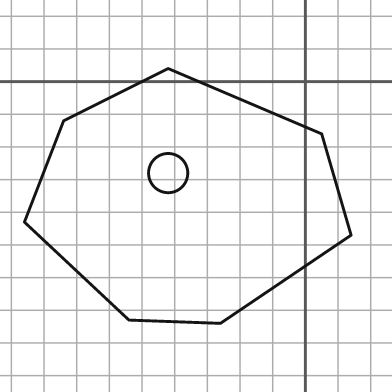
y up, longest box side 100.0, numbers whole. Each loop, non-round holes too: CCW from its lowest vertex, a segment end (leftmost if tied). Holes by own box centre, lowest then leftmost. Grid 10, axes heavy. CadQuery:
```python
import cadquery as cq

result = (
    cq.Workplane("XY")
    .moveTo(-26.0, -74.0)
    .lineTo(14.0, -47.0)
    .lineTo(5.0, -16.0)
    .lineTo(-42.0, 4.0)
    .lineTo(-74.0, -12.0)
    .lineTo(-86.0, -43.0)
    .lineTo(-54.0, -73.0)
    .close()
    .moveTo(-42.0, -28.0)
    .circle(6.0)
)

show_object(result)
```